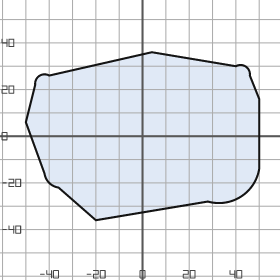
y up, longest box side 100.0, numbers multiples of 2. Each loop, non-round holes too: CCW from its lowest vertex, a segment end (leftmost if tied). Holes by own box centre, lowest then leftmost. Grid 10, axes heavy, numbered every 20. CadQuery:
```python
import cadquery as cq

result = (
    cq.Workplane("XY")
    .moveTo(-20.0, -36.0)
    .lineTo(28.0, -28.0)
    .threePointArc((42.0, -26.0), (50.0, -14.0))
    .lineTo(50.0, 16.0)
    .lineTo(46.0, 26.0)
    .threePointArc((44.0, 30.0), (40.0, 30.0))
    .lineTo(4.0, 36.0)
    .lineTo(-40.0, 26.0)
    .threePointArc((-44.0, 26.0), (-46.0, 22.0))
    .lineTo(-50.0, 6.0)
    .lineTo(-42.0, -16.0)
    .threePointArc((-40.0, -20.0), (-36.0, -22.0))
    .close()
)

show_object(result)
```